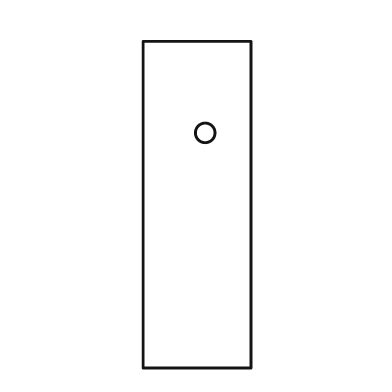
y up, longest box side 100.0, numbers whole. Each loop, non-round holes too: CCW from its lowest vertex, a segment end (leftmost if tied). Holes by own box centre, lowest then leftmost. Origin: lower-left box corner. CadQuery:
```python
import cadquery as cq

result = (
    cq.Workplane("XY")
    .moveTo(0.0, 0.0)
    .lineTo(33.0, 0.0)
    .lineTo(33.0, 100.0)
    .lineTo(0.0, 100.0)
    .close()
    .moveTo(19.0, 72.0)
    .circle(3.0)
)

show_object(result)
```